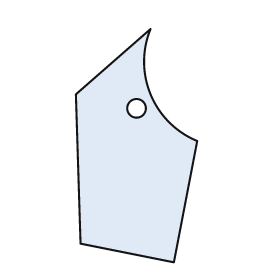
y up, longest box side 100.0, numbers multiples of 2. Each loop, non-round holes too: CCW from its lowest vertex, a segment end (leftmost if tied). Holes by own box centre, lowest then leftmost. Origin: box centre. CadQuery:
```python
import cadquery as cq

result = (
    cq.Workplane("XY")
    .moveTo(16.0, -50.0)
    .lineTo(26.0, 2.0)
    .threePointArc((6.0, 22.0), (6.0, 50.0))
    .lineTo(-26.0, 22.0)
    .lineTo(-24.0, -42.0)
    .close()
    .moveTo(0.0, 16.0)
    .circle(4.0)
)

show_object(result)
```